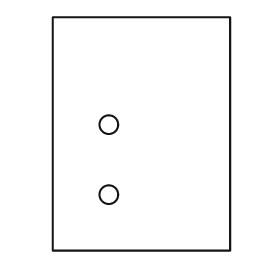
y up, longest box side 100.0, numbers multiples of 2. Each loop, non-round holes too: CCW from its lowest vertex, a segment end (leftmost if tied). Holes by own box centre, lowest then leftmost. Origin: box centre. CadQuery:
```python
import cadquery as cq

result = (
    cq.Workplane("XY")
    .moveTo(-38.0, -50.0)
    .lineTo(38.0, -50.0)
    .lineTo(38.0, 50.0)
    .lineTo(-38.0, 50.0)
    .close()
    .moveTo(-14.0, -26.0)
    .circle(4.0)
    .moveTo(-14.0, 4.0)
    .circle(4.0)
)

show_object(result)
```